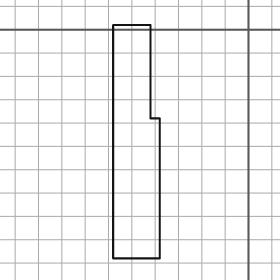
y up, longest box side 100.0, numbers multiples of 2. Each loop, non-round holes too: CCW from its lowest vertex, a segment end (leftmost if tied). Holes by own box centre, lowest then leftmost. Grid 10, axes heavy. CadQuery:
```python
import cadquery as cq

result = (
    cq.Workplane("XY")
    .moveTo(-58.0, -98.0)
    .lineTo(-38.0, -98.0)
    .lineTo(-38.0, -38.0)
    .lineTo(-42.0, -38.0)
    .lineTo(-42.0, 2.0)
    .lineTo(-58.0, 2.0)
    .close()
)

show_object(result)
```